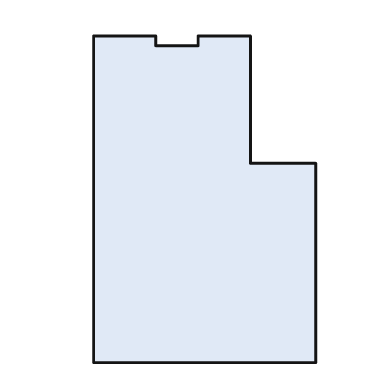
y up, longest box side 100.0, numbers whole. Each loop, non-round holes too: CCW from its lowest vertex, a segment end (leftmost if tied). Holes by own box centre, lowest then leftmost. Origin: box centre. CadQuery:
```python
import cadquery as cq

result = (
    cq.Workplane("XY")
    .moveTo(-34.0, -50.0)
    .lineTo(34.0, -50.0)
    .lineTo(34.0, 11.0)
    .lineTo(14.0, 11.0)
    .lineTo(14.0, 50.0)
    .lineTo(-2.0, 50.0)
    .lineTo(-2.0, 47.0)
    .lineTo(-15.0, 47.0)
    .lineTo(-15.0, 50.0)
    .lineTo(-34.0, 50.0)
    .close()
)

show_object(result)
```